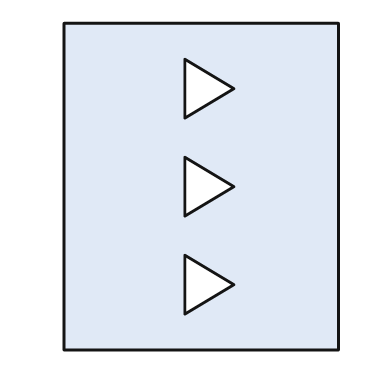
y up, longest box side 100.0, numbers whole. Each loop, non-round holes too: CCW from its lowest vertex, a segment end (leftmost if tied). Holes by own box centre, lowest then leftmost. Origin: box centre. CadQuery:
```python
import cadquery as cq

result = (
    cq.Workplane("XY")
    .moveTo(-42.0, -50.0)
    .lineTo(42.0, -50.0)
    .lineTo(42.0, 50.0)
    .lineTo(-42.0, 50.0)
    .close()
    .moveTo(-5.0, -39.0)
    .lineTo(10.0, -30.0)
    .lineTo(-5.0, -21.0)
    .close()
    .moveTo(-5.0, -9.0)
    .lineTo(10.0, 0.0)
    .lineTo(-5.0, 9.0)
    .close()
    .moveTo(-5.0, 21.0)
    .lineTo(10.0, 30.0)
    .lineTo(-5.0, 39.0)
    .close()
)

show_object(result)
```